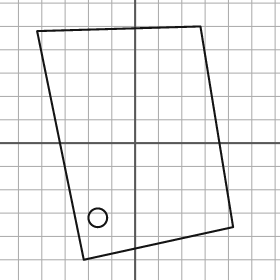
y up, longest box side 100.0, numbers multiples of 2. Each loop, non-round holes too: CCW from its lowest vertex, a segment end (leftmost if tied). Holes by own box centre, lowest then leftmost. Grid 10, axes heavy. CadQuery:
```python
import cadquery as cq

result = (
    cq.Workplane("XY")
    .moveTo(-22.0, -50.0)
    .lineTo(42.0, -36.0)
    .lineTo(28.0, 50.0)
    .lineTo(-42.0, 48.0)
    .close()
    .moveTo(-16.0, -32.0)
    .circle(4.0)
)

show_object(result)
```